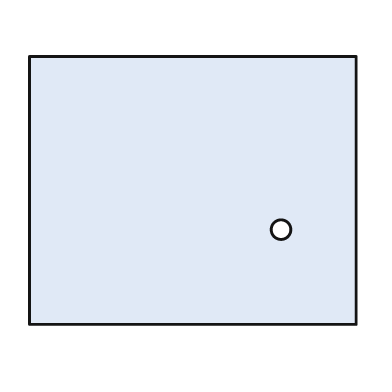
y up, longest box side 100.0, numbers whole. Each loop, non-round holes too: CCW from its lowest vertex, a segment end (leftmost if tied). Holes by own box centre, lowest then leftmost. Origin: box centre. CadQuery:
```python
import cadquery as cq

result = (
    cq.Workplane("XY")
    .moveTo(-50.0, -41.0)
    .lineTo(50.0, -41.0)
    .lineTo(50.0, 41.0)
    .lineTo(-50.0, 41.0)
    .close()
    .moveTo(27.0, -12.0)
    .circle(3.0)
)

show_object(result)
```